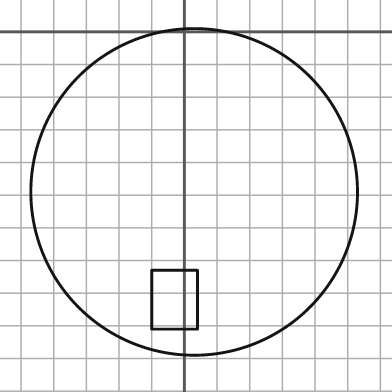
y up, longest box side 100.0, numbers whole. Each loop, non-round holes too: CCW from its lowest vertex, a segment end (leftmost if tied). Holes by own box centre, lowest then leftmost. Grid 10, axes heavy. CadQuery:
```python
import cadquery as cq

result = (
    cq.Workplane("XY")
    .moveTo(3.0, -49.0)
    .circle(50.0)
    .moveTo(-10.0, -91.0)
    .lineTo(4.0, -91.0)
    .lineTo(4.0, -73.0)
    .lineTo(-10.0, -73.0)
    .close()
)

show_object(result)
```